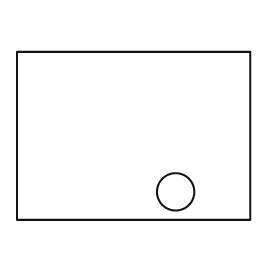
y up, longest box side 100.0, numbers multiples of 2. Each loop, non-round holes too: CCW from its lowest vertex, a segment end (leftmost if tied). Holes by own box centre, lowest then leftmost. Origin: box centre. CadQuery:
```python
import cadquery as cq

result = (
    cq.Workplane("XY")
    .moveTo(-50.0, -36.0)
    .lineTo(50.0, -36.0)
    .lineTo(50.0, 36.0)
    .lineTo(-50.0, 36.0)
    .close()
    .moveTo(18.0, -24.0)
    .circle(8.0)
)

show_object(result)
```